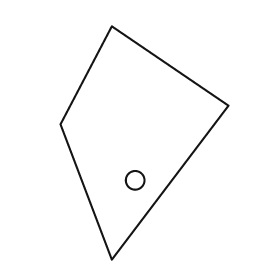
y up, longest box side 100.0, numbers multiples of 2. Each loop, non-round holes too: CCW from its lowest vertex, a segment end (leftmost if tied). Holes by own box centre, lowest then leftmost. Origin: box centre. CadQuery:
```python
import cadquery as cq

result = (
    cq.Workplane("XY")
    .moveTo(-14.0, -50.0)
    .lineTo(36.0, 16.0)
    .lineTo(-14.0, 50.0)
    .lineTo(-36.0, 8.0)
    .close()
    .moveTo(-4.0, -16.0)
    .circle(4.0)
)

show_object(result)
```